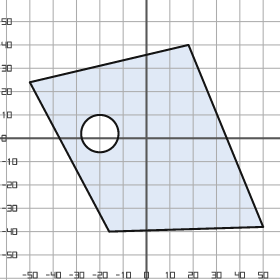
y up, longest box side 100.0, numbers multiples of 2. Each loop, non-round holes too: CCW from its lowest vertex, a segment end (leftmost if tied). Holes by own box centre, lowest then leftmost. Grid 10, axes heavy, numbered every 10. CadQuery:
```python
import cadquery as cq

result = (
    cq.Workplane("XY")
    .moveTo(-16.0, -40.0)
    .lineTo(50.0, -38.0)
    .lineTo(18.0, 40.0)
    .lineTo(-50.0, 24.0)
    .close()
    .moveTo(-20.0, 2.0)
    .circle(8.0)
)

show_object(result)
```